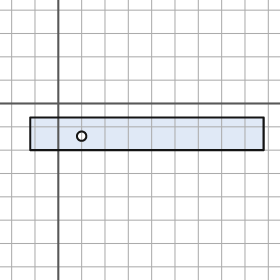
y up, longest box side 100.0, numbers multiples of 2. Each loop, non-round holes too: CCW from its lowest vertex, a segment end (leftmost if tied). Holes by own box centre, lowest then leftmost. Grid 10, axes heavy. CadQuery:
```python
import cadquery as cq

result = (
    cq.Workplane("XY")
    .moveTo(-12.0, -20.0)
    .lineTo(88.0, -20.0)
    .lineTo(88.0, -6.0)
    .lineTo(-12.0, -6.0)
    .close()
    .moveTo(10.0, -14.0)
    .circle(2.0)
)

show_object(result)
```